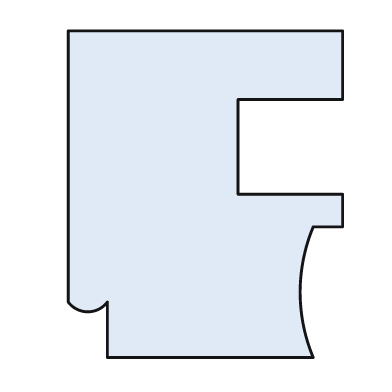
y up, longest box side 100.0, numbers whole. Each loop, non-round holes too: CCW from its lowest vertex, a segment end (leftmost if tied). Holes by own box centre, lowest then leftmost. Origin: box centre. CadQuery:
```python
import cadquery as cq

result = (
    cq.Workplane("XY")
    .moveTo(-30.0, -50.0)
    .lineTo(33.0, -50.0)
    .threePointArc((29.0, -30.0), (33.0, -10.0))
    .lineTo(42.0, -10.0)
    .lineTo(42.0, 0.0)
    .lineTo(10.0, 0.0)
    .lineTo(10.0, 29.0)
    .lineTo(42.0, 29.0)
    .lineTo(42.0, 50.0)
    .lineTo(-42.0, 50.0)
    .lineTo(-42.0, -33.0)
    .threePointArc((-36.0, -36.0), (-30.0, -33.0))
    .close()
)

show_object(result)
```